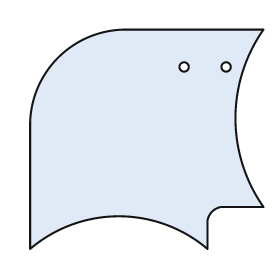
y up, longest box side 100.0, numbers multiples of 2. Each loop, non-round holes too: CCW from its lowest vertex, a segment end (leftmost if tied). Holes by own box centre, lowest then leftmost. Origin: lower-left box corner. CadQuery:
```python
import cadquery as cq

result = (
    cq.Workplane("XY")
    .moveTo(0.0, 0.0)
    .threePointArc((38.0, 14.0), (76.0, 0.0))
    .lineTo(76.0, 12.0)
    .threePointArc((78.0, 16.0), (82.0, 18.0))
    .lineTo(100.0, 18.0)
    .threePointArc((88.0, 56.0), (100.0, 94.0))
    .lineTo(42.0, 94.0)
    .threePointArc((12.0, 82.0), (0.0, 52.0))
    .close()
    .moveTo(66.0, 78.0)
    .circle(2.0)
    .moveTo(84.0, 78.0)
    .circle(2.0)
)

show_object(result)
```